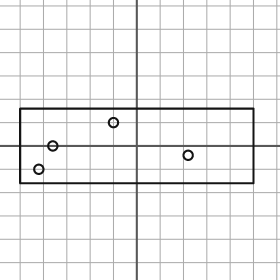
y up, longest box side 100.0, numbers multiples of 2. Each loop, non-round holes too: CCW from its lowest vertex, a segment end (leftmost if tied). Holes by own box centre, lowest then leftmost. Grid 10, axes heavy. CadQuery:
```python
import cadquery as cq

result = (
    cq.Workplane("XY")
    .moveTo(-50.0, -16.0)
    .lineTo(50.0, -16.0)
    .lineTo(50.0, 16.0)
    .lineTo(-50.0, 16.0)
    .close()
    .moveTo(-42.0, -10.0)
    .circle(2.0)
    .moveTo(22.0, -4.0)
    .circle(2.0)
    .moveTo(-36.0, 0.0)
    .circle(2.0)
    .moveTo(-10.0, 10.0)
    .circle(2.0)
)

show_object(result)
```